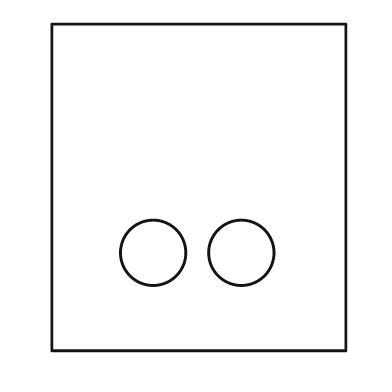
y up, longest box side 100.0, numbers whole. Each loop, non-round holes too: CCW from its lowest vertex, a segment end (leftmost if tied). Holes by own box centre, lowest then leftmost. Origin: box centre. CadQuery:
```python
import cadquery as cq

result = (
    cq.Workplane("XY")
    .moveTo(-45.0, -50.0)
    .lineTo(45.0, -50.0)
    .lineTo(45.0, 50.0)
    .lineTo(-45.0, 50.0)
    .close()
    .moveTo(-14.0, -20.0)
    .circle(10.0)
    .moveTo(13.0, -20.0)
    .circle(10.0)
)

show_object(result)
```